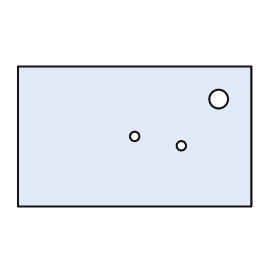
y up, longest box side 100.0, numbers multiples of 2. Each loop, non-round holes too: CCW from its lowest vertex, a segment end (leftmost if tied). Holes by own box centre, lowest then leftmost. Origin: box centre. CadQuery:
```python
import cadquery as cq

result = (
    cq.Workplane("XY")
    .moveTo(-50.0, -30.0)
    .lineTo(50.0, -30.0)
    .lineTo(50.0, 30.0)
    .lineTo(-50.0, 30.0)
    .close()
    .moveTo(20.0, -4.0)
    .circle(2.0)
    .moveTo(0.0, 0.0)
    .circle(2.0)
    .moveTo(36.0, 16.0)
    .circle(4.0)
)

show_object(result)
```